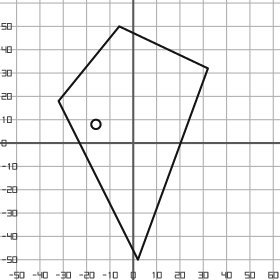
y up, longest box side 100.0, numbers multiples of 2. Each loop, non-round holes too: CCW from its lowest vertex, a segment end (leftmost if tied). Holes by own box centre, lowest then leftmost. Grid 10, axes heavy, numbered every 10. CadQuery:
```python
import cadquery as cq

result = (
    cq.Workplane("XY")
    .moveTo(2.0, -50.0)
    .lineTo(32.0, 32.0)
    .lineTo(-6.0, 50.0)
    .lineTo(-32.0, 18.0)
    .close()
    .moveTo(-16.0, 8.0)
    .circle(2.0)
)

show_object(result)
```